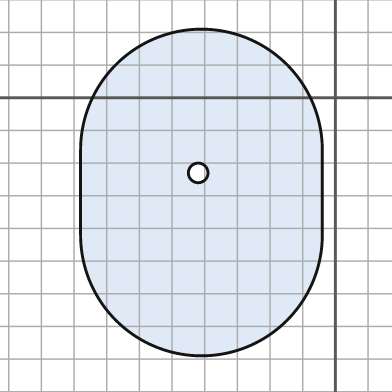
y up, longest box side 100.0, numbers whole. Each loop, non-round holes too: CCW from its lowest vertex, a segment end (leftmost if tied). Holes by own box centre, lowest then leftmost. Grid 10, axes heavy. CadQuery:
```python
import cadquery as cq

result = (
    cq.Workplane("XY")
    .moveTo(-78.0, -42.0)
    .threePointArc((-41.0, -79.0), (-4.0, -42.0))
    .lineTo(-4.0, -16.0)
    .threePointArc((-41.0, 21.0), (-78.0, -16.0))
    .close()
    .moveTo(-42.0, -23.0)
    .circle(3.0)
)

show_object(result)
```